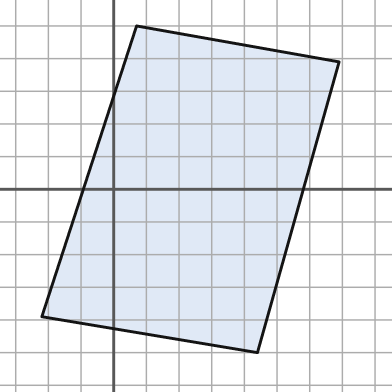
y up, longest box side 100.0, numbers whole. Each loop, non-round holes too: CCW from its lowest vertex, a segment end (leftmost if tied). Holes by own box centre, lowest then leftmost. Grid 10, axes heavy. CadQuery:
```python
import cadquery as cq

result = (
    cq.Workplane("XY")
    .moveTo(44.0, -50.0)
    .lineTo(69.0, 39.0)
    .lineTo(7.0, 50.0)
    .lineTo(-22.0, -39.0)
    .close()
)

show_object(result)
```